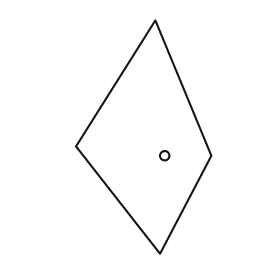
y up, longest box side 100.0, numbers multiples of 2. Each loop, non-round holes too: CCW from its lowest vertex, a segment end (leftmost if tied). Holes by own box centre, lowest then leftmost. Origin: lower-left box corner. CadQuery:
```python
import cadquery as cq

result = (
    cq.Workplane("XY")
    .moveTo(36.0, 0.0)
    .lineTo(58.0, 42.0)
    .lineTo(34.0, 100.0)
    .lineTo(0.0, 46.0)
    .close()
    .moveTo(38.0, 42.0)
    .circle(2.0)
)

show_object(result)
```